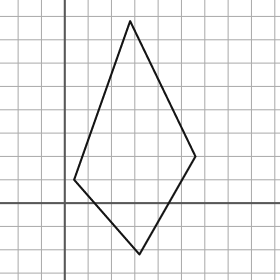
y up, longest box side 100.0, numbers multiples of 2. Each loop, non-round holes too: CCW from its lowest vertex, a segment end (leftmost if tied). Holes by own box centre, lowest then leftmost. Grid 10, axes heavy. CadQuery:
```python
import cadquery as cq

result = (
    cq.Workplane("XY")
    .moveTo(32.0, -22.0)
    .lineTo(56.0, 20.0)
    .lineTo(28.0, 78.0)
    .lineTo(4.0, 10.0)
    .close()
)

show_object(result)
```